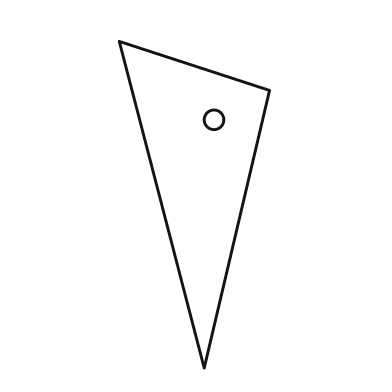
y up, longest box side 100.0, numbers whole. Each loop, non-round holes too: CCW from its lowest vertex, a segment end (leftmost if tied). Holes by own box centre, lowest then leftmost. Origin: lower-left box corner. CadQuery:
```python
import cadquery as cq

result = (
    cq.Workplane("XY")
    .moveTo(26.0, 0.0)
    .lineTo(46.0, 85.0)
    .lineTo(0.0, 100.0)
    .close()
    .moveTo(29.0, 76.0)
    .circle(3.0)
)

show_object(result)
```